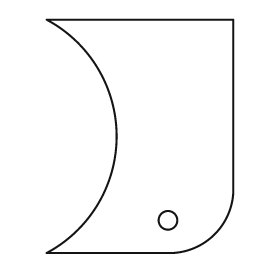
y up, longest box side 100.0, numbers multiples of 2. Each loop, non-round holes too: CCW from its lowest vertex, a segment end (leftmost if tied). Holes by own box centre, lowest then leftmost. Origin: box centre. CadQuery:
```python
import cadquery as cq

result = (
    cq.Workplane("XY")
    .moveTo(-40.0, -50.0)
    .lineTo(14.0, -50.0)
    .threePointArc((32.0, -42.0), (40.0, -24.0))
    .lineTo(40.0, 50.0)
    .lineTo(-40.0, 50.0)
    .threePointArc((-10.0, 0.0), (-40.0, -50.0))
    .close()
    .moveTo(12.0, -36.0)
    .circle(4.0)
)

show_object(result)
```